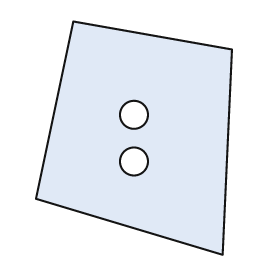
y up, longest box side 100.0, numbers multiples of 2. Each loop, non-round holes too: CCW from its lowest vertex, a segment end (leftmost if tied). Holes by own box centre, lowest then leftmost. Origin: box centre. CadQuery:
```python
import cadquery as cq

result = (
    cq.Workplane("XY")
    .moveTo(38.0, -50.0)
    .lineTo(42.0, 38.0)
    .lineTo(-26.0, 50.0)
    .lineTo(-42.0, -26.0)
    .close()
    .moveTo(0.0, -10.0)
    .circle(6.0)
    .moveTo(0.0, 10.0)
    .circle(6.0)
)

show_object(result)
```